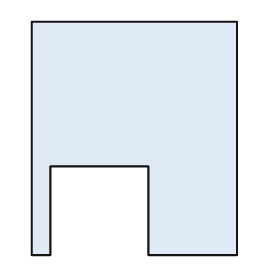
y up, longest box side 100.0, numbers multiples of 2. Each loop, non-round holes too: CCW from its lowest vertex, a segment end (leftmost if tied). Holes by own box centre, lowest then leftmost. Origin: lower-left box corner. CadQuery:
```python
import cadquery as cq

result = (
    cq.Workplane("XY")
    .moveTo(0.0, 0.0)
    .lineTo(8.0, 0.0)
    .lineTo(8.0, 38.0)
    .lineTo(50.0, 38.0)
    .lineTo(50.0, 0.0)
    .lineTo(88.0, 0.0)
    .lineTo(88.0, 100.0)
    .lineTo(0.0, 100.0)
    .close()
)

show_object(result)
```